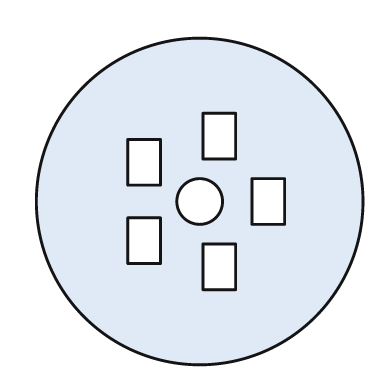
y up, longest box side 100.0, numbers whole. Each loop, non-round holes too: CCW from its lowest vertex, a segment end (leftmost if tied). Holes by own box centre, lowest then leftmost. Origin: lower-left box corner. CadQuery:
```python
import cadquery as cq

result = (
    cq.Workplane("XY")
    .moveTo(50.0, 50.0)
    .circle(50.0)
    .moveTo(51.0, 23.0)
    .lineTo(61.0, 23.0)
    .lineTo(61.0, 37.0)
    .lineTo(51.0, 37.0)
    .close()
    .moveTo(28.0, 31.0)
    .lineTo(38.0, 31.0)
    .lineTo(38.0, 45.0)
    .lineTo(28.0, 45.0)
    .close()
    .moveTo(50.0, 50.0)
    .circle(7.0)
    .moveTo(66.0, 43.0)
    .lineTo(76.0, 43.0)
    .lineTo(76.0, 57.0)
    .lineTo(66.0, 57.0)
    .close()
    .moveTo(28.0, 55.0)
    .lineTo(38.0, 55.0)
    .lineTo(38.0, 69.0)
    .lineTo(28.0, 69.0)
    .close()
    .moveTo(51.0, 63.0)
    .lineTo(61.0, 63.0)
    .lineTo(61.0, 77.0)
    .lineTo(51.0, 77.0)
    .close()
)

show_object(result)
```